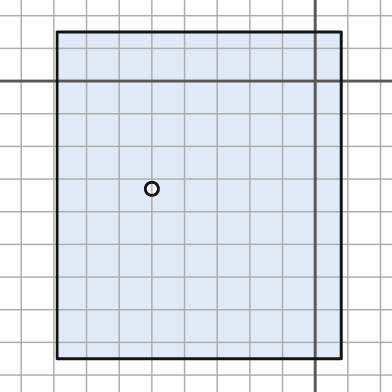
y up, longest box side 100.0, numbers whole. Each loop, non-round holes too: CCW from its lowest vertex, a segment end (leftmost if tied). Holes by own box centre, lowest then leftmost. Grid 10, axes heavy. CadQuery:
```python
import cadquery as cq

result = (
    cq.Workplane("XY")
    .moveTo(-79.0, -85.0)
    .lineTo(8.0, -85.0)
    .lineTo(8.0, 15.0)
    .lineTo(-79.0, 15.0)
    .close()
    .moveTo(-50.0, -33.0)
    .circle(2.0)
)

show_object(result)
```